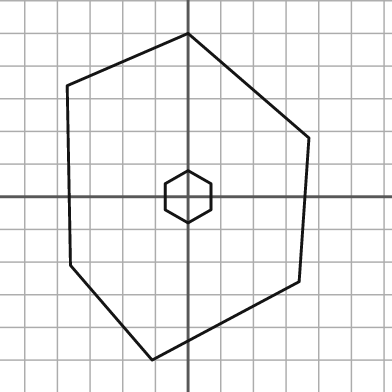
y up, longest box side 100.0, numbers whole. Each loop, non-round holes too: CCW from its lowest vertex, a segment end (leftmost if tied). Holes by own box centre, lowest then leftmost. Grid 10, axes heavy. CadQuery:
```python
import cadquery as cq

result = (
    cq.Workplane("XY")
    .moveTo(-11.0, -50.0)
    .lineTo(34.0, -26.0)
    .lineTo(37.0, 18.0)
    .lineTo(0.0, 50.0)
    .lineTo(-37.0, 34.0)
    .lineTo(-36.0, -21.0)
    .close()
    .moveTo(0.0, -8.0)
    .lineTo(7.0, -4.0)
    .lineTo(7.0, 4.0)
    .lineTo(0.0, 8.0)
    .lineTo(-7.0, 4.0)
    .lineTo(-7.0, -4.0)
    .close()
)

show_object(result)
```